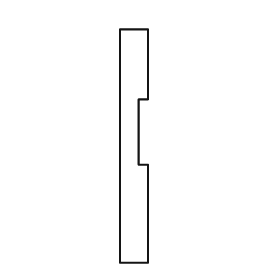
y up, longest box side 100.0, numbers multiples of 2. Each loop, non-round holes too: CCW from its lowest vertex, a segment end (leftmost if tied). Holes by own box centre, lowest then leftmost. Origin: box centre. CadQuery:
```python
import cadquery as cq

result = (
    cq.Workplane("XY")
    .moveTo(-6.0, -50.0)
    .lineTo(6.0, -50.0)
    .lineTo(6.0, -8.0)
    .lineTo(2.0, -8.0)
    .lineTo(2.0, 20.0)
    .lineTo(6.0, 20.0)
    .lineTo(6.0, 50.0)
    .lineTo(-6.0, 50.0)
    .close()
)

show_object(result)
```